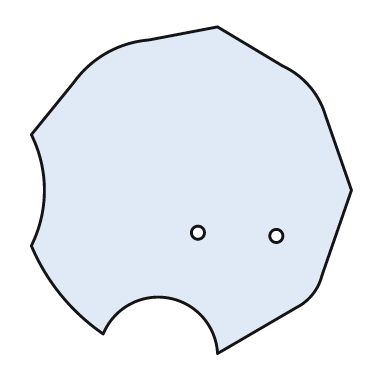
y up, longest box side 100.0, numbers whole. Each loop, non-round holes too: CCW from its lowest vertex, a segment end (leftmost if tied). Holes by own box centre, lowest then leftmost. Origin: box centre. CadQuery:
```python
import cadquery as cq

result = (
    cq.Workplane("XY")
    .moveTo(8.0, -50.0)
    .lineTo(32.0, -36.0)
    .threePointArc((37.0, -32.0), (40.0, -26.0))
    .lineTo(49.0, 0.0)
    .lineTo(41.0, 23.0)
    .threePointArc((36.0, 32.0), (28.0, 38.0))
    .lineTo(8.0, 50.0)
    .lineTo(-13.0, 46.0)
    .threePointArc((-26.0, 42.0), (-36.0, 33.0))
    .lineTo(-49.0, 17.0)
    .threePointArc((-45.0, 0.0), (-49.0, -17.0))
    .threePointArc((-40.0, -32.0), (-27.0, -44.0))
    .threePointArc((-7.0, -33.0), (8.0, -50.0))
    .close()
    .moveTo(26.0, -14.0)
    .circle(2.0)
    .moveTo(2.0, -13.0)
    .circle(2.0)
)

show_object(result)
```